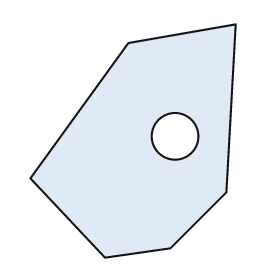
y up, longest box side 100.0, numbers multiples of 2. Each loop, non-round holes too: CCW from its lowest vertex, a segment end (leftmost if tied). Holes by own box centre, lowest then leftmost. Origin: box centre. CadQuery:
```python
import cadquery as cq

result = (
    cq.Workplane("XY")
    .moveTo(-12.0, -50.0)
    .lineTo(16.0, -46.0)
    .lineTo(40.0, -22.0)
    .lineTo(44.0, 50.0)
    .lineTo(-2.0, 42.0)
    .lineTo(-44.0, -16.0)
    .close()
    .moveTo(18.0, 2.0)
    .circle(10.0)
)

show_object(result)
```